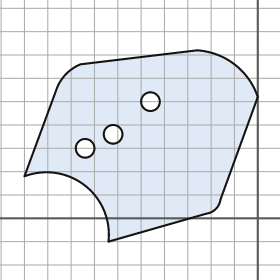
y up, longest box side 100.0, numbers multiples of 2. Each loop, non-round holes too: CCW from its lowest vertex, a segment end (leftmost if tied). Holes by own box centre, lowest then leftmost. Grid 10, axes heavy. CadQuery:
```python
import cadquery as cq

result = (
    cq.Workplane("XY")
    .moveTo(-64.0, -10.0)
    .lineTo(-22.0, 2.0)
    .threePointArc((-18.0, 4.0), (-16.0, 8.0))
    .lineTo(0.0, 52.0)
    .threePointArc((-10.0, 66.0), (-26.0, 72.0))
    .lineTo(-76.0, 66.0)
    .threePointArc((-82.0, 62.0), (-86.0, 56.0))
    .lineTo(-100.0, 18.0)
    .threePointArc((-74.0, 14.0), (-64.0, -10.0))
    .close()
    .moveTo(-74.0, 30.0)
    .circle(4.0)
    .moveTo(-62.0, 36.0)
    .circle(4.0)
    .moveTo(-46.0, 50.0)
    .circle(4.0)
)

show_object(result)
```